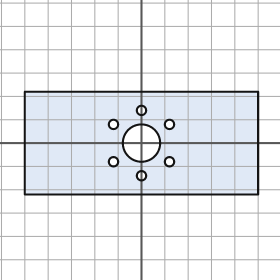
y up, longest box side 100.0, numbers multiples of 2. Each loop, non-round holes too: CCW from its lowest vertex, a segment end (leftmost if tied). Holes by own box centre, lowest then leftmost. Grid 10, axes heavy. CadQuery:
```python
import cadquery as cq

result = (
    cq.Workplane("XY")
    .moveTo(-50.0, -22.0)
    .lineTo(50.0, -22.0)
    .lineTo(50.0, 22.0)
    .lineTo(-50.0, 22.0)
    .close()
    .moveTo(0.0, -14.0)
    .circle(2.0)
    .moveTo(-12.0, -8.0)
    .circle(2.0)
    .moveTo(12.0, -8.0)
    .circle(2.0)
    .moveTo(0.0, 0.0)
    .circle(8.0)
    .moveTo(-12.0, 8.0)
    .circle(2.0)
    .moveTo(12.0, 8.0)
    .circle(2.0)
    .moveTo(0.0, 14.0)
    .circle(2.0)
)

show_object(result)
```